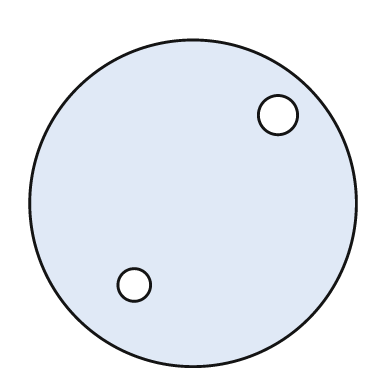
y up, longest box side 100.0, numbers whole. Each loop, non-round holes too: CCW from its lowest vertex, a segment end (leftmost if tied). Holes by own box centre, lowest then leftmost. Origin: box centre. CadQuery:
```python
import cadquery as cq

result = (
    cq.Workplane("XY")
    .moveTo(0.0, 0.0)
    .circle(50.0)
    .moveTo(-18.0, -25.0)
    .circle(5.0)
    .moveTo(26.0, 27.0)
    .circle(6.0)
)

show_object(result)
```